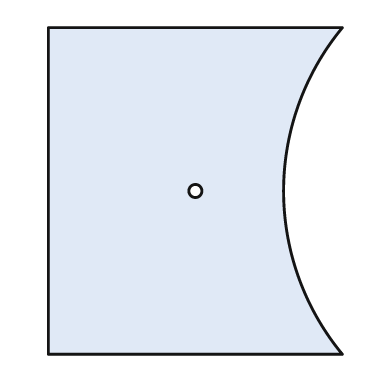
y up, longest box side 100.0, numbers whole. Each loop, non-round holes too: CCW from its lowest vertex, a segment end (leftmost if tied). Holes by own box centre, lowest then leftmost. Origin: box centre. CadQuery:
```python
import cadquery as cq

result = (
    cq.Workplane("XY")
    .moveTo(-45.0, -50.0)
    .lineTo(45.0, -50.0)
    .threePointArc((27.0, 0.0), (45.0, 50.0))
    .lineTo(-45.0, 50.0)
    .close()
    .moveTo(0.0, 0.0)
    .circle(2.0)
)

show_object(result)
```